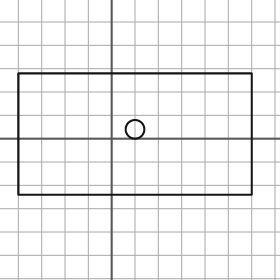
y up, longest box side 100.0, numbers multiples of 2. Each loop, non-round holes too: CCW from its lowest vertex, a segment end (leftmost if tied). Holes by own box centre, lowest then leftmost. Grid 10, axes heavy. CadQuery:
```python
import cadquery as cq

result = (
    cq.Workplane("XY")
    .moveTo(-40.0, -24.0)
    .lineTo(60.0, -24.0)
    .lineTo(60.0, 28.0)
    .lineTo(-40.0, 28.0)
    .close()
    .moveTo(10.0, 4.0)
    .circle(4.0)
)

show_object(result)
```